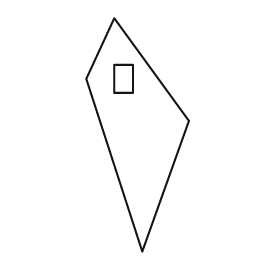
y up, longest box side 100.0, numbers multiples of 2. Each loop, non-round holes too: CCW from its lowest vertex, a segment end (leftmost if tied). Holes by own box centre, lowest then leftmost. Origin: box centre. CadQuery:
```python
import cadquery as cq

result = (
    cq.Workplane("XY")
    .moveTo(2.0, -50.0)
    .lineTo(22.0, 6.0)
    .lineTo(-10.0, 50.0)
    .lineTo(-22.0, 24.0)
    .close()
    .moveTo(-10.0, 18.0)
    .lineTo(-2.0, 18.0)
    .lineTo(-2.0, 30.0)
    .lineTo(-10.0, 30.0)
    .close()
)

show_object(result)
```